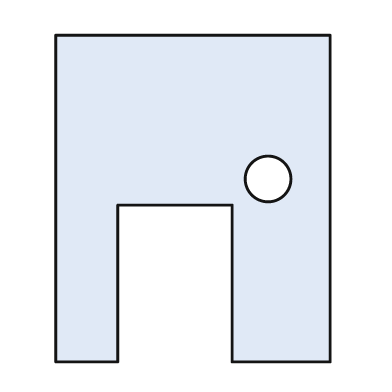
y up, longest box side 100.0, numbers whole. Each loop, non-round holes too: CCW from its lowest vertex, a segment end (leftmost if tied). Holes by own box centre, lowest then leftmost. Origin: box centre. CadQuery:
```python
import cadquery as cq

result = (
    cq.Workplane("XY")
    .moveTo(-42.0, -50.0)
    .lineTo(-23.0, -50.0)
    .lineTo(-23.0, -2.0)
    .lineTo(12.0, -2.0)
    .lineTo(12.0, -50.0)
    .lineTo(42.0, -50.0)
    .lineTo(42.0, 50.0)
    .lineTo(-42.0, 50.0)
    .close()
    .moveTo(23.0, 6.0)
    .circle(7.0)
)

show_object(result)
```